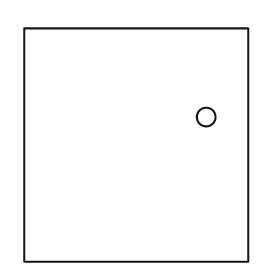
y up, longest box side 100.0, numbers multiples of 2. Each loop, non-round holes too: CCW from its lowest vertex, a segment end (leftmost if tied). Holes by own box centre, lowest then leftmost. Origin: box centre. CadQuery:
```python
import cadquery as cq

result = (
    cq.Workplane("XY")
    .moveTo(-48.0, -50.0)
    .lineTo(48.0, -50.0)
    .lineTo(48.0, 50.0)
    .lineTo(-48.0, 50.0)
    .close()
    .moveTo(30.0, 12.0)
    .circle(4.0)
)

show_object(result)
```